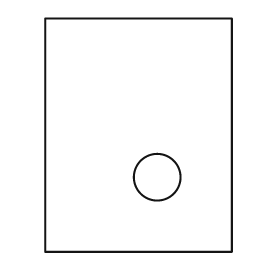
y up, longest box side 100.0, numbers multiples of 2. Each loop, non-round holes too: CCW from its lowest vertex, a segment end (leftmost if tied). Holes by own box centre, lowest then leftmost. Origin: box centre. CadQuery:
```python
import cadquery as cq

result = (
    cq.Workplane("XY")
    .moveTo(-40.0, -50.0)
    .lineTo(40.0, -50.0)
    .lineTo(40.0, 50.0)
    .lineTo(-40.0, 50.0)
    .close()
    .moveTo(8.0, -18.0)
    .circle(10.0)
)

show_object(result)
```